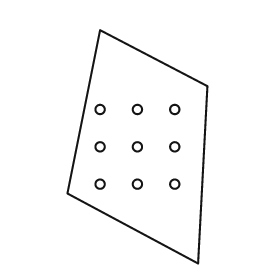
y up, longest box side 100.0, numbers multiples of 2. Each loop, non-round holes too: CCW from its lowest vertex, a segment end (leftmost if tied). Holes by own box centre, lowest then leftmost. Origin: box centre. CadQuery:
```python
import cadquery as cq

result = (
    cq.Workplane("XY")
    .moveTo(26.0, -50.0)
    .lineTo(30.0, 26.0)
    .lineTo(-16.0, 50.0)
    .lineTo(-30.0, -20.0)
    .close()
    .moveTo(-16.0, -16.0)
    .circle(2.0)
    .moveTo(0.0, -16.0)
    .circle(2.0)
    .moveTo(16.0, -16.0)
    .circle(2.0)
    .moveTo(-16.0, 0.0)
    .circle(2.0)
    .moveTo(0.0, 0.0)
    .circle(2.0)
    .moveTo(16.0, 0.0)
    .circle(2.0)
    .moveTo(-16.0, 16.0)
    .circle(2.0)
    .moveTo(0.0, 16.0)
    .circle(2.0)
    .moveTo(16.0, 16.0)
    .circle(2.0)
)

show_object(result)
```